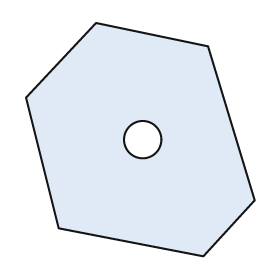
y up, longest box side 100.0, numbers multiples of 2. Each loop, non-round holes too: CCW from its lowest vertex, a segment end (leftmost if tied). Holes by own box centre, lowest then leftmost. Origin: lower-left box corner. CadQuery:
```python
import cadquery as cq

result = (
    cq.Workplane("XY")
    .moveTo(76.0, 0.0)
    .lineTo(98.0, 24.0)
    .lineTo(78.0, 90.0)
    .lineTo(30.0, 100.0)
    .lineTo(0.0, 68.0)
    .lineTo(14.0, 12.0)
    .close()
    .moveTo(50.0, 50.0)
    .circle(8.0)
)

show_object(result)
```